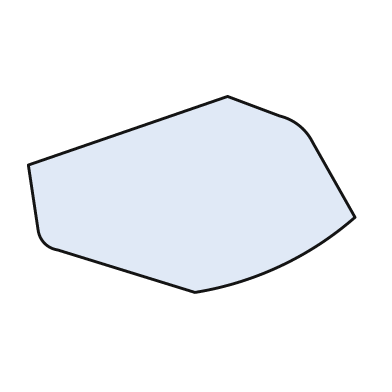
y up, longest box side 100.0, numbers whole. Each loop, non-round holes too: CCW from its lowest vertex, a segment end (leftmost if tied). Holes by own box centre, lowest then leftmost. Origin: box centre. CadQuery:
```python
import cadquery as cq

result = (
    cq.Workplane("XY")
    .moveTo(1.0, -30.0)
    .threePointArc((27.0, -22.0), (50.0, -7.0))
    .lineTo(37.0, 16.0)
    .threePointArc((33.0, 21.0), (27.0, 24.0))
    .lineTo(11.0, 30.0)
    .lineTo(-50.0, 9.0)
    .lineTo(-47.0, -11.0)
    .threePointArc((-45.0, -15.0), (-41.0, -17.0))
    .close()
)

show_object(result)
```